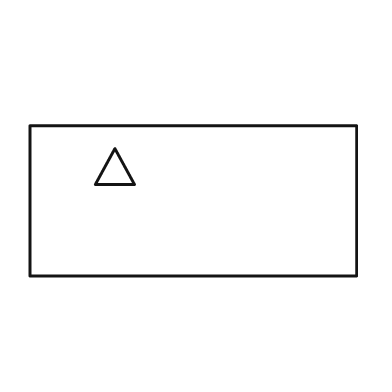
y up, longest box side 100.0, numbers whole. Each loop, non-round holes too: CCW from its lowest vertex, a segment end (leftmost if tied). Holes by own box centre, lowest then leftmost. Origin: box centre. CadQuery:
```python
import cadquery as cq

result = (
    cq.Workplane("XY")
    .moveTo(-50.0, -23.0)
    .lineTo(50.0, -23.0)
    .lineTo(50.0, 23.0)
    .lineTo(-50.0, 23.0)
    .close()
    .moveTo(-30.0, 5.0)
    .lineTo(-18.0, 5.0)
    .lineTo(-24.0, 16.0)
    .close()
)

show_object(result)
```